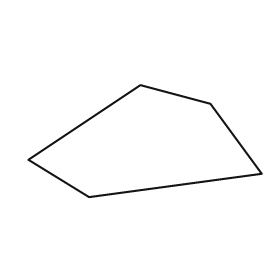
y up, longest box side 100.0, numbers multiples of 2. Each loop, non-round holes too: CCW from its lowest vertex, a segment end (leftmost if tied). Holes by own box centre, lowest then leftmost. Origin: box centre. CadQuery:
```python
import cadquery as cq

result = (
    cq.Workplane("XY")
    .moveTo(-24.0, -24.0)
    .lineTo(50.0, -14.0)
    .lineTo(28.0, 16.0)
    .lineTo(-2.0, 24.0)
    .lineTo(-50.0, -8.0)
    .close()
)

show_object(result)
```